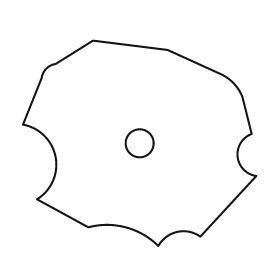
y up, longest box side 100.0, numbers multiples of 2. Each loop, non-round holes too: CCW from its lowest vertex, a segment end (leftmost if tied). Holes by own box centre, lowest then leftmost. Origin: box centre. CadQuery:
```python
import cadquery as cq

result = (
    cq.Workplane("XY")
    .moveTo(8.0, -44.0)
    .threePointArc((16.0, -38.0), (26.0, -40.0))
    .lineTo(50.0, -14.0)
    .threePointArc((42.0, -6.0), (48.0, 4.0))
    .lineTo(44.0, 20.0)
    .threePointArc((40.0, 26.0), (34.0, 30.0))
    .lineTo(12.0, 40.0)
    .lineTo(-20.0, 44.0)
    .lineTo(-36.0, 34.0)
    .threePointArc((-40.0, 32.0), (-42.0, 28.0))
    .lineTo(-50.0, 8.0)
    .threePointArc((-36.0, -6.0), (-44.0, -24.0))
    .lineTo(-22.0, -36.0)
    .threePointArc((-6.0, -36.0), (8.0, -44.0))
    .close()
    .moveTo(0.0, 0.0)
    .circle(6.0)
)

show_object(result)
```